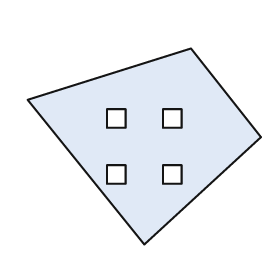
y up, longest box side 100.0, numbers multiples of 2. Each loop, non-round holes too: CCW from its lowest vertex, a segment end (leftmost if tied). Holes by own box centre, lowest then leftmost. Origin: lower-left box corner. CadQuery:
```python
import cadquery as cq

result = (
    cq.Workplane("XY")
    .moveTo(50.0, 0.0)
    .lineTo(100.0, 46.0)
    .lineTo(70.0, 84.0)
    .lineTo(0.0, 62.0)
    .close()
    .moveTo(34.0, 26.0)
    .lineTo(42.0, 26.0)
    .lineTo(42.0, 34.0)
    .lineTo(34.0, 34.0)
    .close()
    .moveTo(58.0, 26.0)
    .lineTo(66.0, 26.0)
    .lineTo(66.0, 34.0)
    .lineTo(58.0, 34.0)
    .close()
    .moveTo(34.0, 50.0)
    .lineTo(42.0, 50.0)
    .lineTo(42.0, 58.0)
    .lineTo(34.0, 58.0)
    .close()
    .moveTo(58.0, 50.0)
    .lineTo(66.0, 50.0)
    .lineTo(66.0, 58.0)
    .lineTo(58.0, 58.0)
    .close()
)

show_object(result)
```